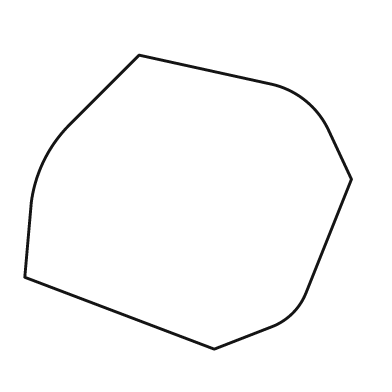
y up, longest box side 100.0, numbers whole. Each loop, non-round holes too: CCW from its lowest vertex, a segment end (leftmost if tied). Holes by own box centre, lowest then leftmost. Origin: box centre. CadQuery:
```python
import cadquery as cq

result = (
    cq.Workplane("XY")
    .moveTo(8.0, -45.0)
    .lineTo(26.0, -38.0)
    .threePointArc((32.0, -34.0), (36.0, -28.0))
    .lineTo(50.0, 7.0)
    .lineTo(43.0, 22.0)
    .threePointArc((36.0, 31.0), (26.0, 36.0))
    .lineTo(-15.0, 45.0)
    .lineTo(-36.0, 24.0)
    .threePointArc((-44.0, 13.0), (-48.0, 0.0))
    .lineTo(-50.0, -23.0)
    .close()
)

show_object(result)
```